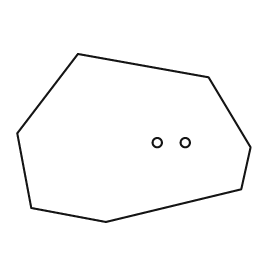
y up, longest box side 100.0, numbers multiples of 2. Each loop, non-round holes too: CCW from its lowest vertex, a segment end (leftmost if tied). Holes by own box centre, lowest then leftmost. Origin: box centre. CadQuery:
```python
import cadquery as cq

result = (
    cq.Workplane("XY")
    .moveTo(-12.0, -36.0)
    .lineTo(46.0, -22.0)
    .lineTo(50.0, -4.0)
    .lineTo(32.0, 26.0)
    .lineTo(-24.0, 36.0)
    .lineTo(-50.0, 2.0)
    .lineTo(-44.0, -30.0)
    .close()
    .moveTo(10.0, -2.0)
    .circle(2.0)
    .moveTo(22.0, -2.0)
    .circle(2.0)
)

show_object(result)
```